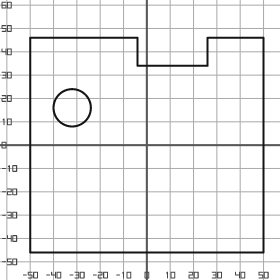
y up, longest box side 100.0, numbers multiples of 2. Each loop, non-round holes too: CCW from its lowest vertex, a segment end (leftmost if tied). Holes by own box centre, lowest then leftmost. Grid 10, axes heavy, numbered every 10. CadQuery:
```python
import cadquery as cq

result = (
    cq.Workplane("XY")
    .moveTo(-50.0, -46.0)
    .lineTo(50.0, -46.0)
    .lineTo(50.0, 46.0)
    .lineTo(26.0, 46.0)
    .lineTo(26.0, 34.0)
    .lineTo(-4.0, 34.0)
    .lineTo(-4.0, 46.0)
    .lineTo(-50.0, 46.0)
    .close()
    .moveTo(-32.0, 16.0)
    .circle(8.0)
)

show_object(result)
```